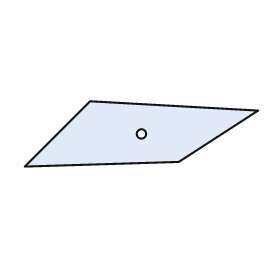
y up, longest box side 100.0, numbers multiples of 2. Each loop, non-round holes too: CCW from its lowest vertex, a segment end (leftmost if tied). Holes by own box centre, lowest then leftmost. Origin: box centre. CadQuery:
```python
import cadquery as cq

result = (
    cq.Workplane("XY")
    .moveTo(-50.0, -14.0)
    .lineTo(16.0, -12.0)
    .lineTo(50.0, 10.0)
    .lineTo(-22.0, 14.0)
    .close()
    .moveTo(0.0, 0.0)
    .circle(2.0)
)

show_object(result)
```